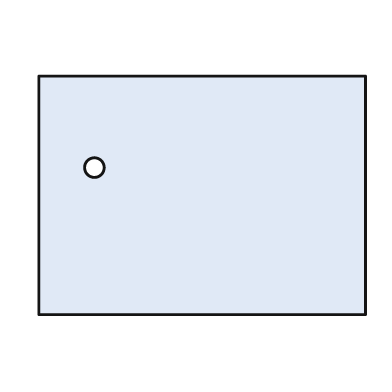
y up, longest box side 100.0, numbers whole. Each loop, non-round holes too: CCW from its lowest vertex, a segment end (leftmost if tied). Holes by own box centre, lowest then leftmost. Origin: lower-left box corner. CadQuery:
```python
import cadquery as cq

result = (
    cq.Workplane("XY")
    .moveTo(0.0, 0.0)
    .lineTo(100.0, 0.0)
    .lineTo(100.0, 73.0)
    .lineTo(0.0, 73.0)
    .close()
    .moveTo(17.0, 45.0)
    .circle(3.0)
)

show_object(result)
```